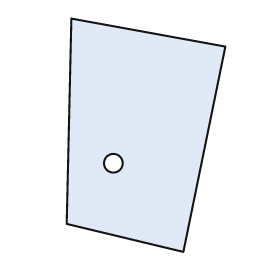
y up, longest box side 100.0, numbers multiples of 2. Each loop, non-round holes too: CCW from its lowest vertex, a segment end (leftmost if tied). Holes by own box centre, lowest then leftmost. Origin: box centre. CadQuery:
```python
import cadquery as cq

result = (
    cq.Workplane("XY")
    .moveTo(16.0, -50.0)
    .lineTo(34.0, 38.0)
    .lineTo(-32.0, 50.0)
    .lineTo(-34.0, -38.0)
    .close()
    .moveTo(-14.0, -12.0)
    .circle(4.0)
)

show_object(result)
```